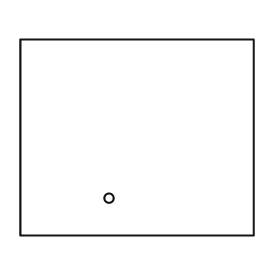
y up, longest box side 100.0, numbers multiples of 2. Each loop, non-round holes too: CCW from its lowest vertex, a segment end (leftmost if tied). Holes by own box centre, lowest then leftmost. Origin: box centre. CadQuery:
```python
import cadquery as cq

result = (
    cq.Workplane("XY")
    .moveTo(-50.0, -42.0)
    .lineTo(50.0, -42.0)
    .lineTo(50.0, 42.0)
    .lineTo(-50.0, 42.0)
    .close()
    .moveTo(-12.0, -26.0)
    .circle(2.0)
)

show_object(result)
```